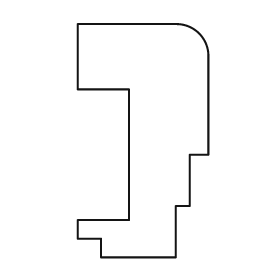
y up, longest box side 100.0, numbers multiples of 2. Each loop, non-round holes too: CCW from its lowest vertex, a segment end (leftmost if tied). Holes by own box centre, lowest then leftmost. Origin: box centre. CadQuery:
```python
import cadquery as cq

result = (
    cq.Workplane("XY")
    .moveTo(-18.0, -50.0)
    .lineTo(14.0, -50.0)
    .lineTo(14.0, -28.0)
    .lineTo(20.0, -28.0)
    .lineTo(20.0, -6.0)
    .lineTo(28.0, -6.0)
    .lineTo(28.0, 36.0)
    .threePointArc((24.0, 46.0), (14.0, 50.0))
    .lineTo(-28.0, 50.0)
    .lineTo(-28.0, 22.0)
    .lineTo(-6.0, 22.0)
    .lineTo(-6.0, -34.0)
    .lineTo(-28.0, -34.0)
    .lineTo(-28.0, -42.0)
    .lineTo(-18.0, -42.0)
    .close()
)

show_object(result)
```